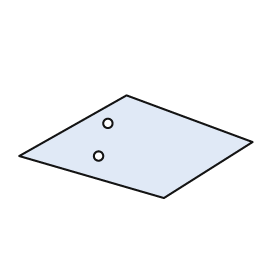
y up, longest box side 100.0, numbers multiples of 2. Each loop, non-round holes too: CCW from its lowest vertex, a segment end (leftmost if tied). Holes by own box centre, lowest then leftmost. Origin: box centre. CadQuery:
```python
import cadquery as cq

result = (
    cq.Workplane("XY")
    .moveTo(12.0, -22.0)
    .lineTo(50.0, 2.0)
    .lineTo(-4.0, 22.0)
    .lineTo(-50.0, -4.0)
    .close()
    .moveTo(-16.0, -4.0)
    .circle(2.0)
    .moveTo(-12.0, 10.0)
    .circle(2.0)
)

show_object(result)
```